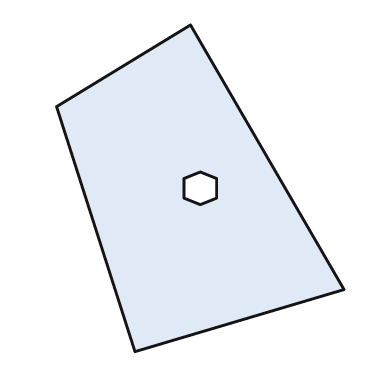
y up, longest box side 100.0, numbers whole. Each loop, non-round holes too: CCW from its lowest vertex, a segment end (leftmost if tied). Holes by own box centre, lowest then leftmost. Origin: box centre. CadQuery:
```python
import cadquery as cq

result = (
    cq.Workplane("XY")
    .moveTo(-20.0, -50.0)
    .lineTo(44.0, -31.0)
    .lineTo(-3.0, 50.0)
    .lineTo(-44.0, 25.0)
    .close()
    .moveTo(0.0, -5.0)
    .lineTo(5.0, -3.0)
    .lineTo(5.0, 3.0)
    .lineTo(0.0, 5.0)
    .lineTo(-5.0, 3.0)
    .lineTo(-5.0, -3.0)
    .close()
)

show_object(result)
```